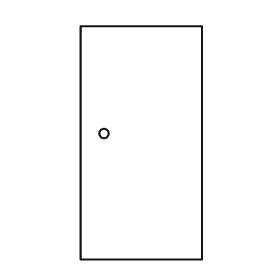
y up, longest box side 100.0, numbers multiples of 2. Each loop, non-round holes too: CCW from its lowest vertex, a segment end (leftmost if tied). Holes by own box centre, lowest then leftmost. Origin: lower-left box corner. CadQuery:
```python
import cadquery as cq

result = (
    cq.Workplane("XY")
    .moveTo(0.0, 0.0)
    .lineTo(52.0, 0.0)
    .lineTo(52.0, 100.0)
    .lineTo(0.0, 100.0)
    .close()
    .moveTo(10.0, 54.0)
    .circle(2.0)
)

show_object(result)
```